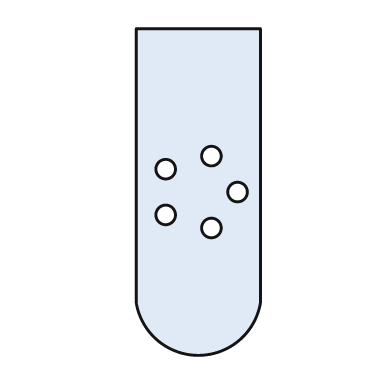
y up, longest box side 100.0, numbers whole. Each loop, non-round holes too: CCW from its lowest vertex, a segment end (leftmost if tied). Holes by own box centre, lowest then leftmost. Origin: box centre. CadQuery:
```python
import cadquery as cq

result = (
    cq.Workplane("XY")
    .moveTo(-19.0, -34.0)
    .threePointArc((0.0, -50.0), (19.0, -34.0))
    .lineTo(19.0, 50.0)
    .lineTo(-19.0, 50.0)
    .close()
    .moveTo(4.0, -11.0)
    .circle(3.0)
    .moveTo(-10.0, -7.0)
    .circle(3.0)
    .moveTo(12.0, 0.0)
    .circle(3.0)
    .moveTo(-10.0, 7.0)
    .circle(3.0)
    .moveTo(4.0, 11.0)
    .circle(3.0)
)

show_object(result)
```